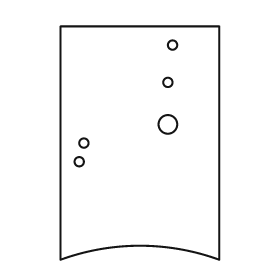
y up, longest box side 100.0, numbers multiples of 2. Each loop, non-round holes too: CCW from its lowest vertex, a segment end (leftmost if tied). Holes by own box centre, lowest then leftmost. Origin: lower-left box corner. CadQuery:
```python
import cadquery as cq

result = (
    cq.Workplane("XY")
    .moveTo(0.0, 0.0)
    .threePointArc((34.0, 6.0), (68.0, 0.0))
    .lineTo(68.0, 100.0)
    .lineTo(0.0, 100.0)
    .close()
    .moveTo(8.0, 42.0)
    .circle(2.0)
    .moveTo(10.0, 50.0)
    .circle(2.0)
    .moveTo(46.0, 58.0)
    .circle(4.0)
    .moveTo(46.0, 76.0)
    .circle(2.0)
    .moveTo(48.0, 92.0)
    .circle(2.0)
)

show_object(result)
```